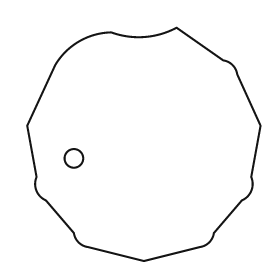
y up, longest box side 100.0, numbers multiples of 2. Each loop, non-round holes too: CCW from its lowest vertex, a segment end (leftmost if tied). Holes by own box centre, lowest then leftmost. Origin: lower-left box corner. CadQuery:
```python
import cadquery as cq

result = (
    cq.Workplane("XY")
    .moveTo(50.0, 0.0)
    .lineTo(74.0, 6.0)
    .threePointArc((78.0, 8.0), (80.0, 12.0))
    .lineTo(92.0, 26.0)
    .threePointArc((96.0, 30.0), (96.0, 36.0))
    .lineTo(100.0, 58.0)
    .lineTo(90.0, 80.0)
    .threePointArc((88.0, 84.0), (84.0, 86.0))
    .lineTo(64.0, 100.0)
    .threePointArc((50.0, 96.0), (36.0, 98.0))
    .threePointArc((22.0, 94.0), (12.0, 84.0))
    .lineTo(0.0, 58.0)
    .lineTo(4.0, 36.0)
    .threePointArc((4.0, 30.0), (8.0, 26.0))
    .lineTo(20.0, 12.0)
    .threePointArc((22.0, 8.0), (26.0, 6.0))
    .close()
    .moveTo(20.0, 44.0)
    .circle(4.0)
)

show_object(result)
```